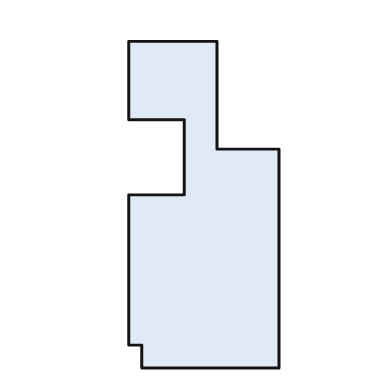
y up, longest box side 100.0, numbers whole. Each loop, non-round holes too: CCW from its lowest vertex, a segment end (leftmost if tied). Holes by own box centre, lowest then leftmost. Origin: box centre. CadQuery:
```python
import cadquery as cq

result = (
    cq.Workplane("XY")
    .moveTo(-19.0, -50.0)
    .lineTo(23.0, -50.0)
    .lineTo(23.0, 17.0)
    .lineTo(4.0, 17.0)
    .lineTo(4.0, 50.0)
    .lineTo(-23.0, 50.0)
    .lineTo(-23.0, 26.0)
    .lineTo(-6.0, 26.0)
    .lineTo(-6.0, 3.0)
    .lineTo(-23.0, 3.0)
    .lineTo(-23.0, -43.0)
    .lineTo(-19.0, -43.0)
    .close()
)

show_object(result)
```